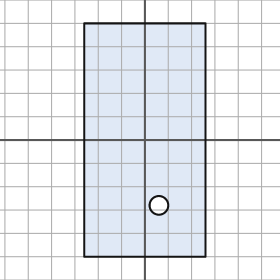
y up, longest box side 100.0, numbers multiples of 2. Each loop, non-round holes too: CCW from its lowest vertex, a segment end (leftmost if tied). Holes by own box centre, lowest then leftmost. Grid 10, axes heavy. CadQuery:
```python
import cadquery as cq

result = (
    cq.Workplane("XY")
    .moveTo(-26.0, -50.0)
    .lineTo(26.0, -50.0)
    .lineTo(26.0, 50.0)
    .lineTo(-26.0, 50.0)
    .close()
    .moveTo(6.0, -28.0)
    .circle(4.0)
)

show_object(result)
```